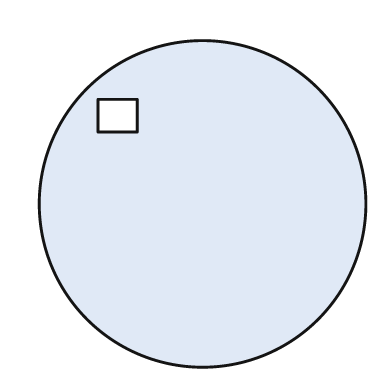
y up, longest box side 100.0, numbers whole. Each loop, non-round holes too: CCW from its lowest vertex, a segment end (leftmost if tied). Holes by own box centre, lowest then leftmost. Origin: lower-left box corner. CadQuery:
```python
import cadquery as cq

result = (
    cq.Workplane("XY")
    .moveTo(50.0, 50.0)
    .circle(50.0)
    .moveTo(18.0, 72.0)
    .lineTo(30.0, 72.0)
    .lineTo(30.0, 82.0)
    .lineTo(18.0, 82.0)
    .close()
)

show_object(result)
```